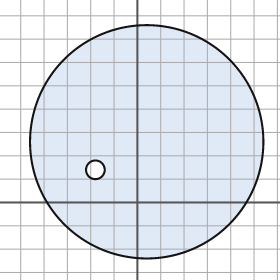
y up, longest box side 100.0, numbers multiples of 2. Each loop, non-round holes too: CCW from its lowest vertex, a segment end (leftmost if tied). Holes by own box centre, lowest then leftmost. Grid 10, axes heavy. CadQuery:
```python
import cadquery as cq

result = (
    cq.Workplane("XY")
    .moveTo(4.0, 26.0)
    .circle(50.0)
    .moveTo(-18.0, 14.0)
    .circle(4.0)
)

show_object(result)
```